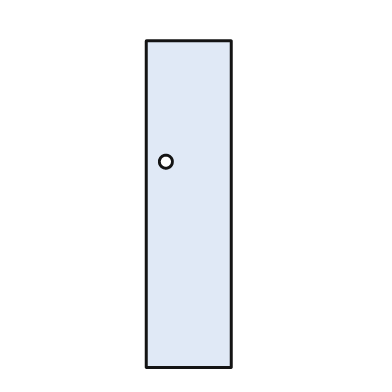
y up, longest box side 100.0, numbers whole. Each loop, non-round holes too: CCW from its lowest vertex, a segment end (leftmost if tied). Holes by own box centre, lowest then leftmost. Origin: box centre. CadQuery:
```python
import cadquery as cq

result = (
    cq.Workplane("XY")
    .moveTo(-13.0, -50.0)
    .lineTo(13.0, -50.0)
    .lineTo(13.0, 50.0)
    .lineTo(-13.0, 50.0)
    .close()
    .moveTo(-7.0, 13.0)
    .circle(2.0)
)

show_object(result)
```